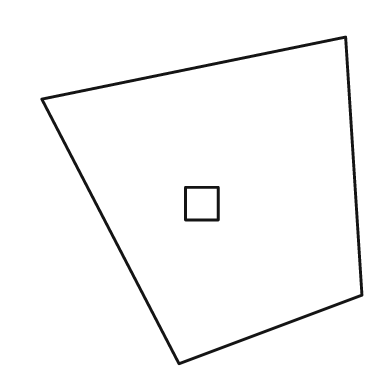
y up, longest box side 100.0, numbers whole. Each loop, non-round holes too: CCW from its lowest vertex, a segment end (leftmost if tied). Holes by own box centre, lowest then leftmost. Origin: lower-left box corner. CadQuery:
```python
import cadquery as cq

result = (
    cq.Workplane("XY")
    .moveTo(42.0, 0.0)
    .lineTo(98.0, 21.0)
    .lineTo(93.0, 100.0)
    .lineTo(0.0, 81.0)
    .close()
    .moveTo(44.0, 44.0)
    .lineTo(54.0, 44.0)
    .lineTo(54.0, 54.0)
    .lineTo(44.0, 54.0)
    .close()
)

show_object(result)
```